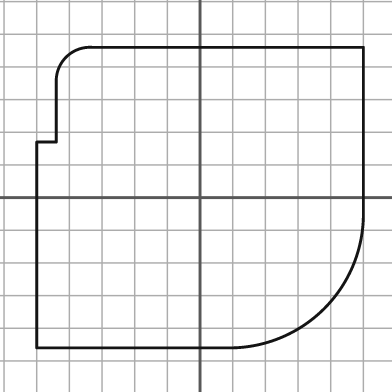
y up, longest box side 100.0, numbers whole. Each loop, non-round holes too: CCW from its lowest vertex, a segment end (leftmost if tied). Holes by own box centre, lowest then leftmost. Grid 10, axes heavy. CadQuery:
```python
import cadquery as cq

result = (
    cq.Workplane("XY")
    .moveTo(-50.0, -46.0)
    .lineTo(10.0, -46.0)
    .threePointArc((38.0, -34.0), (50.0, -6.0))
    .lineTo(50.0, 46.0)
    .lineTo(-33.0, 46.0)
    .threePointArc((-41.0, 43.0), (-44.0, 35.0))
    .lineTo(-44.0, 17.0)
    .lineTo(-50.0, 17.0)
    .close()
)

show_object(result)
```